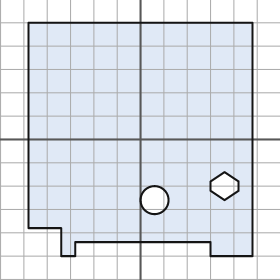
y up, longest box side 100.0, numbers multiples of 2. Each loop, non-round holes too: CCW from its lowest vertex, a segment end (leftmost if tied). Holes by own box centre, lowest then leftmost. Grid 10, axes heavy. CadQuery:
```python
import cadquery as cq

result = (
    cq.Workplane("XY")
    .moveTo(-34.0, -50.0)
    .lineTo(-28.0, -50.0)
    .lineTo(-28.0, -44.0)
    .lineTo(30.0, -44.0)
    .lineTo(30.0, -50.0)
    .lineTo(48.0, -50.0)
    .lineTo(48.0, 50.0)
    .lineTo(-48.0, 50.0)
    .lineTo(-48.0, -38.0)
    .lineTo(-34.0, -38.0)
    .close()
    .moveTo(6.0, -26.0)
    .circle(6.0)
    .moveTo(36.0, -26.0)
    .lineTo(42.0, -22.0)
    .lineTo(42.0, -18.0)
    .lineTo(36.0, -14.0)
    .lineTo(30.0, -18.0)
    .lineTo(30.0, -22.0)
    .close()
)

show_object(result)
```